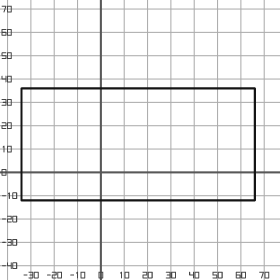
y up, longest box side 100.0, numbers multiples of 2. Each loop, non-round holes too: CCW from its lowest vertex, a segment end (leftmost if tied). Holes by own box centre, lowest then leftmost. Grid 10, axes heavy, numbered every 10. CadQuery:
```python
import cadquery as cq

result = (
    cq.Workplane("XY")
    .moveTo(-34.0, -12.0)
    .lineTo(66.0, -12.0)
    .lineTo(66.0, 36.0)
    .lineTo(-34.0, 36.0)
    .close()
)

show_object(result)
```